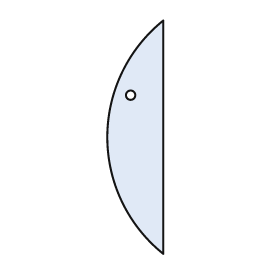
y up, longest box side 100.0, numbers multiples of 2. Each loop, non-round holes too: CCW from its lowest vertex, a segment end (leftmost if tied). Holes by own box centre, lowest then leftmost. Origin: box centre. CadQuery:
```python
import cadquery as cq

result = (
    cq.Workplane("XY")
    .moveTo(12.0, -50.0)
    .lineTo(12.0, 50.0)
    .threePointArc((-12.0, 0.0), (12.0, -50.0))
    .close()
    .moveTo(-2.0, 18.0)
    .circle(2.0)
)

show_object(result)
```